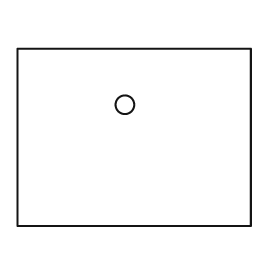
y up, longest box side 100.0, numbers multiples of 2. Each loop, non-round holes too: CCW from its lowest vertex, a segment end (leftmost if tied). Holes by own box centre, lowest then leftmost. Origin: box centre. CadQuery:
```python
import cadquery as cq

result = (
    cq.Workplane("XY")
    .moveTo(-50.0, -38.0)
    .lineTo(50.0, -38.0)
    .lineTo(50.0, 38.0)
    .lineTo(-50.0, 38.0)
    .close()
    .moveTo(-4.0, 14.0)
    .circle(4.0)
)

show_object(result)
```